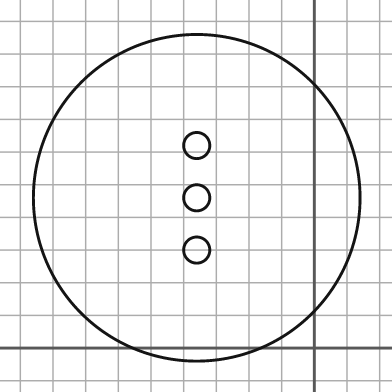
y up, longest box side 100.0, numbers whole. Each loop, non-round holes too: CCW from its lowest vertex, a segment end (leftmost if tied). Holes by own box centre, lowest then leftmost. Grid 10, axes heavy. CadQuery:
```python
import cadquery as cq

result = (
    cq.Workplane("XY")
    .moveTo(-36.0, 46.0)
    .circle(50.0)
    .moveTo(-36.0, 30.0)
    .circle(4.0)
    .moveTo(-36.0, 46.0)
    .circle(4.0)
    .moveTo(-36.0, 62.0)
    .circle(4.0)
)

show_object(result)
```